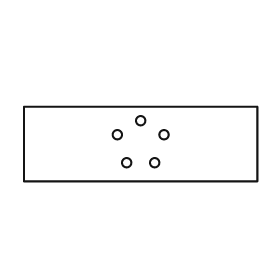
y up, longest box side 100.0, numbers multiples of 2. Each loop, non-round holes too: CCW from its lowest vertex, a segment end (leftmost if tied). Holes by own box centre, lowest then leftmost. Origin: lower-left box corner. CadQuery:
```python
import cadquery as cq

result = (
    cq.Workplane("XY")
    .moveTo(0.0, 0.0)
    .lineTo(100.0, 0.0)
    .lineTo(100.0, 32.0)
    .lineTo(0.0, 32.0)
    .close()
    .moveTo(44.0, 8.0)
    .circle(2.0)
    .moveTo(56.0, 8.0)
    .circle(2.0)
    .moveTo(40.0, 20.0)
    .circle(2.0)
    .moveTo(60.0, 20.0)
    .circle(2.0)
    .moveTo(50.0, 26.0)
    .circle(2.0)
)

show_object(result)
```